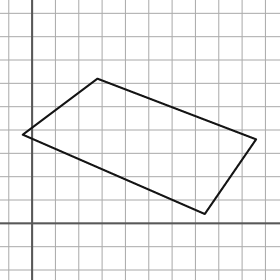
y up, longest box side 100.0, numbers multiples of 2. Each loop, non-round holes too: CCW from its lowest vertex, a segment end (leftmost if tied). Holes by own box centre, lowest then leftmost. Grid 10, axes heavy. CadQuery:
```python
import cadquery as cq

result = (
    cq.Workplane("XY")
    .moveTo(74.0, 4.0)
    .lineTo(96.0, 36.0)
    .lineTo(28.0, 62.0)
    .lineTo(-4.0, 38.0)
    .close()
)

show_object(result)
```